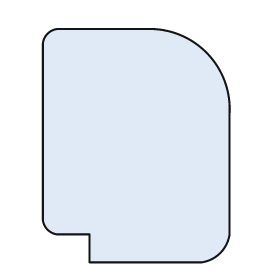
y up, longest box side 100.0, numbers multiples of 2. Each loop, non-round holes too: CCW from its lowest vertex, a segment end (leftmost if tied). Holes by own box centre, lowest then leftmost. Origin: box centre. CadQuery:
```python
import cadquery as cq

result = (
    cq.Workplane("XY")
    .moveTo(-20.0, -50.0)
    .lineTo(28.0, -50.0)
    .threePointArc((36.0, -46.0), (40.0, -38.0))
    .lineTo(40.0, 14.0)
    .threePointArc((30.0, 40.0), (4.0, 50.0))
    .lineTo(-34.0, 50.0)
    .threePointArc((-38.0, 48.0), (-40.0, 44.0))
    .lineTo(-40.0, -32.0)
    .threePointArc((-38.0, -36.0), (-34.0, -38.0))
    .lineTo(-20.0, -38.0)
    .close()
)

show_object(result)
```